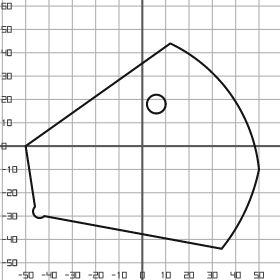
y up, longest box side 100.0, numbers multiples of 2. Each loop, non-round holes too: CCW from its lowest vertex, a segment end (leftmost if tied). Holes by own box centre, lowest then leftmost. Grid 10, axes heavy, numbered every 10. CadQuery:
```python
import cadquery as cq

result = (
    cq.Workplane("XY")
    .moveTo(34.0, -44.0)
    .threePointArc((44.0, -28.0), (50.0, -10.0))
    .threePointArc((38.0, 22.0), (12.0, 44.0))
    .lineTo(-50.0, 0.0)
    .lineTo(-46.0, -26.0)
    .threePointArc((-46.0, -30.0), (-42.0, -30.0))
    .close()
    .moveTo(6.0, 18.0)
    .circle(4.0)
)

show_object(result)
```